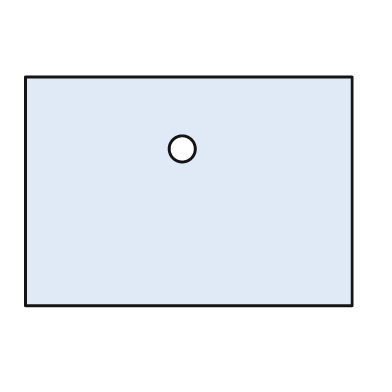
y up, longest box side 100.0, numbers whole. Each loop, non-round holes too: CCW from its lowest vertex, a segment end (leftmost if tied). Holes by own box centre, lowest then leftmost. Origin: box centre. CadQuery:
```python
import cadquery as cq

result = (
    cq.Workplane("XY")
    .moveTo(-50.0, -35.0)
    .lineTo(50.0, -35.0)
    .lineTo(50.0, 35.0)
    .lineTo(-50.0, 35.0)
    .close()
    .moveTo(-2.0, 13.0)
    .circle(4.0)
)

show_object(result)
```